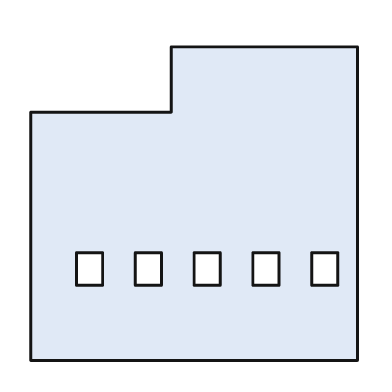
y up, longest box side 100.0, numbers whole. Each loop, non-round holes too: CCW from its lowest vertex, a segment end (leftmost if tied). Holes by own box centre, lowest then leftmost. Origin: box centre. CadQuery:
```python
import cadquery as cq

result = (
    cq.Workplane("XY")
    .moveTo(-50.0, -48.0)
    .lineTo(50.0, -48.0)
    .lineTo(50.0, 48.0)
    .lineTo(-7.0, 48.0)
    .lineTo(-7.0, 28.0)
    .lineTo(-50.0, 28.0)
    .close()
    .moveTo(-36.0, -25.0)
    .lineTo(-28.0, -25.0)
    .lineTo(-28.0, -15.0)
    .lineTo(-36.0, -15.0)
    .close()
    .moveTo(-18.0, -25.0)
    .lineTo(-10.0, -25.0)
    .lineTo(-10.0, -15.0)
    .lineTo(-18.0, -15.0)
    .close()
    .moveTo(0.0, -25.0)
    .lineTo(8.0, -25.0)
    .lineTo(8.0, -15.0)
    .lineTo(0.0, -15.0)
    .close()
    .moveTo(18.0, -25.0)
    .lineTo(26.0, -25.0)
    .lineTo(26.0, -15.0)
    .lineTo(18.0, -15.0)
    .close()
    .moveTo(36.0, -25.0)
    .lineTo(44.0, -25.0)
    .lineTo(44.0, -15.0)
    .lineTo(36.0, -15.0)
    .close()
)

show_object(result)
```